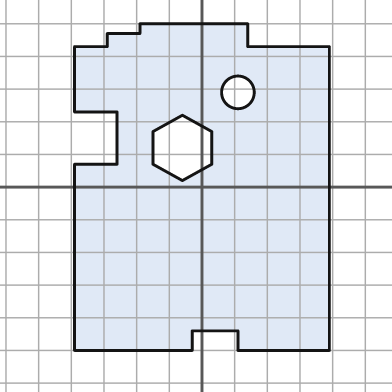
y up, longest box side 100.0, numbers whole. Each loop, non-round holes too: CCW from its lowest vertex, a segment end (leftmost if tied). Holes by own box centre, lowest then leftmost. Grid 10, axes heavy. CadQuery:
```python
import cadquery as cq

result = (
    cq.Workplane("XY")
    .moveTo(-39.0, -50.0)
    .lineTo(-3.0, -50.0)
    .lineTo(-3.0, -44.0)
    .lineTo(11.0, -44.0)
    .lineTo(11.0, -50.0)
    .lineTo(39.0, -50.0)
    .lineTo(39.0, 43.0)
    .lineTo(14.0, 43.0)
    .lineTo(14.0, 50.0)
    .lineTo(-19.0, 50.0)
    .lineTo(-19.0, 47.0)
    .lineTo(-29.0, 47.0)
    .lineTo(-29.0, 43.0)
    .lineTo(-39.0, 43.0)
    .lineTo(-39.0, 23.0)
    .lineTo(-26.0, 23.0)
    .lineTo(-26.0, 7.0)
    .lineTo(-39.0, 7.0)
    .close()
    .moveTo(-6.0, 2.0)
    .lineTo(3.0, 7.0)
    .lineTo(3.0, 17.0)
    .lineTo(-6.0, 22.0)
    .lineTo(-15.0, 17.0)
    .lineTo(-15.0, 7.0)
    .close()
    .moveTo(11.0, 29.0)
    .circle(5.0)
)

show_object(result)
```